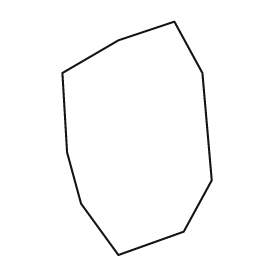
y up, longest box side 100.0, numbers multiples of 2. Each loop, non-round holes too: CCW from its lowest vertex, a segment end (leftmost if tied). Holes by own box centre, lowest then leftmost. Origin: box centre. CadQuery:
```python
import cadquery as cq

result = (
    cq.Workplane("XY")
    .moveTo(-8.0, -50.0)
    .lineTo(20.0, -40.0)
    .lineTo(32.0, -18.0)
    .lineTo(28.0, 28.0)
    .lineTo(16.0, 50.0)
    .lineTo(-8.0, 42.0)
    .lineTo(-32.0, 28.0)
    .lineTo(-30.0, -6.0)
    .lineTo(-24.0, -28.0)
    .close()
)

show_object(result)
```